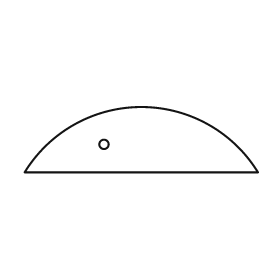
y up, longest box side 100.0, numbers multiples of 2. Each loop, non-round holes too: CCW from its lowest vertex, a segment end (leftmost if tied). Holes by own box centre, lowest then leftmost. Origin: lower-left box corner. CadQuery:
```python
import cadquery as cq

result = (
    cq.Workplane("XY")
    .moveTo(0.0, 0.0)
    .lineTo(100.0, 0.0)
    .threePointArc((50.0, 28.0), (0.0, 0.0))
    .close()
    .moveTo(34.0, 12.0)
    .circle(2.0)
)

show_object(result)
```